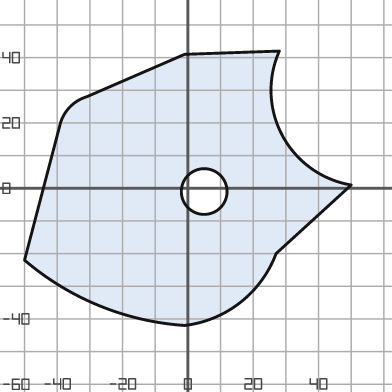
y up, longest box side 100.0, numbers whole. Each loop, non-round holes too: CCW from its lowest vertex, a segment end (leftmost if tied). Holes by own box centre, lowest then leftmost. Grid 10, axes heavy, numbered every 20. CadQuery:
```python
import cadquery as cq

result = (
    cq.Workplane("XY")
    .moveTo(-1.0, -42.0)
    .threePointArc((16.0, -35.0), (27.0, -20.0))
    .lineTo(50.0, 1.0)
    .threePointArc((29.0, 16.0), (28.0, 42.0))
    .lineTo(-1.0, 41.0)
    .lineTo(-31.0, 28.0)
    .threePointArc((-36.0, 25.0), (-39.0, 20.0))
    .lineTo(-50.0, -22.0)
    .threePointArc((-27.0, -36.0), (-1.0, -42.0))
    .close()
    .moveTo(5.0, -1.0)
    .circle(7.0)
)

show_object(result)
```